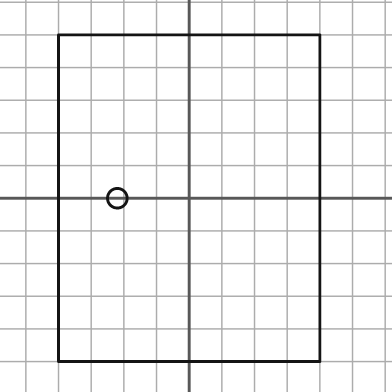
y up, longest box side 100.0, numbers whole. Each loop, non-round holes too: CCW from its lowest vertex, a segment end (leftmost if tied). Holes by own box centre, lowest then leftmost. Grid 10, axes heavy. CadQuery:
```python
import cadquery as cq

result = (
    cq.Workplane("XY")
    .moveTo(-40.0, -50.0)
    .lineTo(40.0, -50.0)
    .lineTo(40.0, 50.0)
    .lineTo(-40.0, 50.0)
    .close()
    .moveTo(-22.0, 0.0)
    .circle(3.0)
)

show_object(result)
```